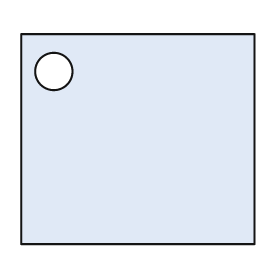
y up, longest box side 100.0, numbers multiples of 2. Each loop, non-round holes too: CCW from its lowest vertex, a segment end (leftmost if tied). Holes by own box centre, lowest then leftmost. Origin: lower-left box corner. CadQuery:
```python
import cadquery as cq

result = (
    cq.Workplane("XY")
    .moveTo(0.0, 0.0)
    .lineTo(100.0, 0.0)
    .lineTo(100.0, 90.0)
    .lineTo(0.0, 90.0)
    .close()
    .moveTo(14.0, 74.0)
    .circle(8.0)
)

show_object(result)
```